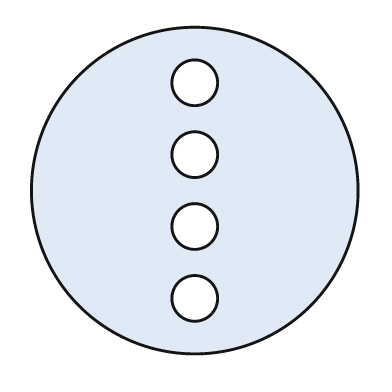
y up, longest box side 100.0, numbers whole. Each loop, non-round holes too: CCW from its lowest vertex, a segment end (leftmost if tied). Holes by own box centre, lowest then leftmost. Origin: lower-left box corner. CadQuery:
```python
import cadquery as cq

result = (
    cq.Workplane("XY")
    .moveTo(50.0, 50.0)
    .circle(50.0)
    .moveTo(50.0, 17.0)
    .circle(7.0)
    .moveTo(50.0, 39.0)
    .circle(7.0)
    .moveTo(50.0, 61.0)
    .circle(7.0)
    .moveTo(50.0, 83.0)
    .circle(7.0)
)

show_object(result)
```